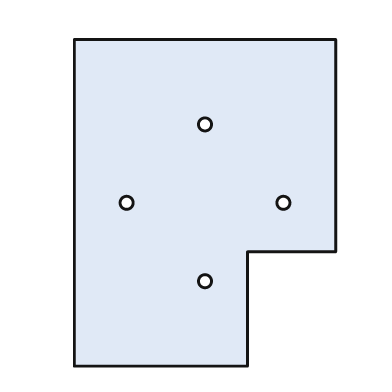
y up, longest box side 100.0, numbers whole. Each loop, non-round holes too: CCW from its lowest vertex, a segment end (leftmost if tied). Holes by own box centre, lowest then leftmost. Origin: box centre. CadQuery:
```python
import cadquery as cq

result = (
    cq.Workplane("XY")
    .moveTo(-40.0, -50.0)
    .lineTo(13.0, -50.0)
    .lineTo(13.0, -15.0)
    .lineTo(40.0, -15.0)
    .lineTo(40.0, 50.0)
    .lineTo(-40.0, 50.0)
    .close()
    .moveTo(0.0, -24.0)
    .circle(2.0)
    .moveTo(-24.0, 0.0)
    .circle(2.0)
    .moveTo(24.0, 0.0)
    .circle(2.0)
    .moveTo(0.0, 24.0)
    .circle(2.0)
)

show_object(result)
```